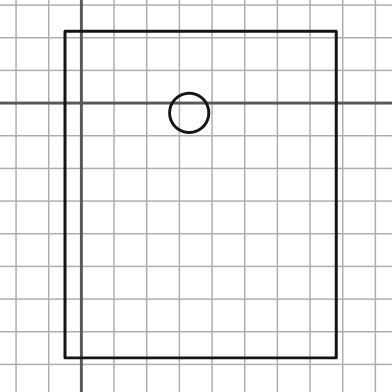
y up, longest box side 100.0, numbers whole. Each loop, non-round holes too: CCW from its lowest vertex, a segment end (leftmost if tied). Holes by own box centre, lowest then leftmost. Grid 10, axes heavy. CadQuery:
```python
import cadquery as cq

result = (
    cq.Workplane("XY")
    .moveTo(-5.0, -78.0)
    .lineTo(78.0, -78.0)
    .lineTo(78.0, 22.0)
    .lineTo(-5.0, 22.0)
    .close()
    .moveTo(33.0, -3.0)
    .circle(6.0)
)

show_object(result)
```